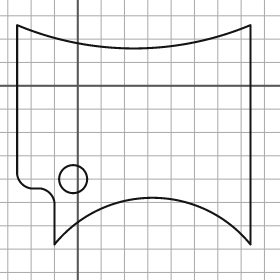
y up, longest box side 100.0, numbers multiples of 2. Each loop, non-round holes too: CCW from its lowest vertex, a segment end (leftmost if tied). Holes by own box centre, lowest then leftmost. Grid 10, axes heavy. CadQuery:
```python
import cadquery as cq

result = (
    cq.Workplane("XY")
    .moveTo(-10.0, -68.0)
    .threePointArc((32.0, -48.0), (74.0, -68.0))
    .lineTo(74.0, 26.0)
    .threePointArc((24.0, 16.0), (-26.0, 26.0))
    .lineTo(-26.0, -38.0)
    .threePointArc((-24.0, -42.0), (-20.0, -44.0))
    .lineTo(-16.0, -44.0)
    .threePointArc((-12.0, -46.0), (-10.0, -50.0))
    .close()
    .moveTo(-2.0, -40.0)
    .circle(6.0)
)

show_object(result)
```